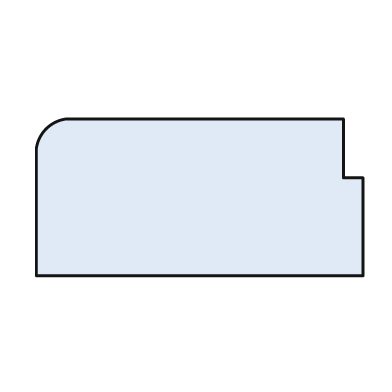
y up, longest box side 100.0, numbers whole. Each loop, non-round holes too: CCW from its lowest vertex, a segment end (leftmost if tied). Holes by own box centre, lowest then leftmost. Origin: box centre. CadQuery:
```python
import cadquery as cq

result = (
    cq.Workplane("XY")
    .moveTo(-50.0, -24.0)
    .lineTo(50.0, -24.0)
    .lineTo(50.0, 6.0)
    .lineTo(44.0, 6.0)
    .lineTo(44.0, 24.0)
    .lineTo(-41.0, 24.0)
    .threePointArc((-47.0, 21.0), (-50.0, 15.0))
    .close()
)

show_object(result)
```